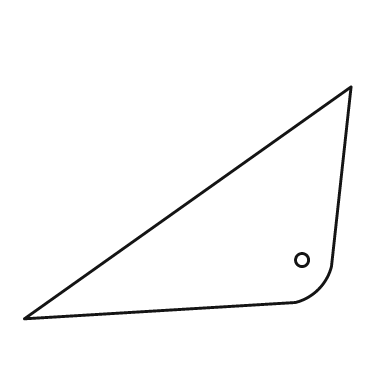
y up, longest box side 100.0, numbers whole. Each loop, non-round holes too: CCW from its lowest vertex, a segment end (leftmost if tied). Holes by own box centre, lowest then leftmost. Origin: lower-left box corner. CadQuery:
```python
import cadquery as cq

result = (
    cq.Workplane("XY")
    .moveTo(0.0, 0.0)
    .lineTo(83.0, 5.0)
    .threePointArc((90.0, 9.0), (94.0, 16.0))
    .lineTo(100.0, 71.0)
    .close()
    .moveTo(85.0, 18.0)
    .circle(2.0)
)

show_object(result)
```